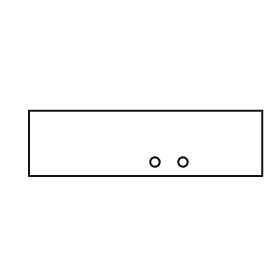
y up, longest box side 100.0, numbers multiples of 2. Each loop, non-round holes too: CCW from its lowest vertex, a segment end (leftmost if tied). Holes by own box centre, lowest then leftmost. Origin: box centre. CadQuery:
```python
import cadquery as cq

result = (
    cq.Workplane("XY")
    .moveTo(-50.0, -14.0)
    .lineTo(50.0, -14.0)
    .lineTo(50.0, 14.0)
    .lineTo(-50.0, 14.0)
    .close()
    .moveTo(4.0, -8.0)
    .circle(2.0)
    .moveTo(16.0, -8.0)
    .circle(2.0)
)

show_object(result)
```